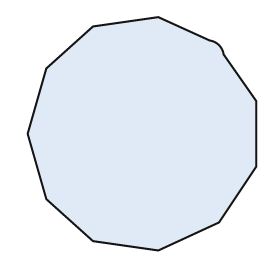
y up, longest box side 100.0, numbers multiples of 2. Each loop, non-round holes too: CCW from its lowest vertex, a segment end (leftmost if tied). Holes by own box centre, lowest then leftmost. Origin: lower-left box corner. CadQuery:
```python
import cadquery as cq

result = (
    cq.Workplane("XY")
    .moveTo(56.0, 0.0)
    .lineTo(82.0, 12.0)
    .lineTo(98.0, 36.0)
    .lineTo(98.0, 64.0)
    .lineTo(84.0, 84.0)
    .threePointArc((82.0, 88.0), (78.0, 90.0))
    .lineTo(56.0, 100.0)
    .lineTo(28.0, 96.0)
    .lineTo(8.0, 78.0)
    .lineTo(0.0, 50.0)
    .lineTo(8.0, 22.0)
    .lineTo(28.0, 4.0)
    .close()
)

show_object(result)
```